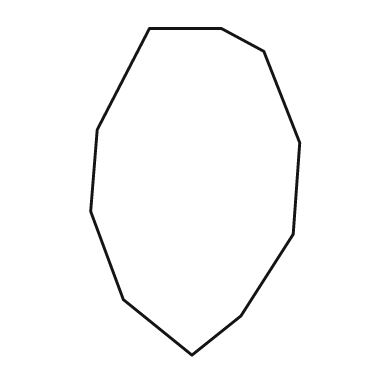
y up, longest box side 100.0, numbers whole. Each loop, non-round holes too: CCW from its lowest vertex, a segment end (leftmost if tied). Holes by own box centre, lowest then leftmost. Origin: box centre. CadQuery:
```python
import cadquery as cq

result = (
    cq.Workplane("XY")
    .moveTo(-1.0, -50.0)
    .lineTo(14.0, -38.0)
    .lineTo(30.0, -13.0)
    .lineTo(32.0, 15.0)
    .lineTo(21.0, 43.0)
    .lineTo(8.0, 50.0)
    .lineTo(-14.0, 50.0)
    .lineTo(-30.0, 19.0)
    .lineTo(-32.0, -6.0)
    .lineTo(-22.0, -33.0)
    .close()
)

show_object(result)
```